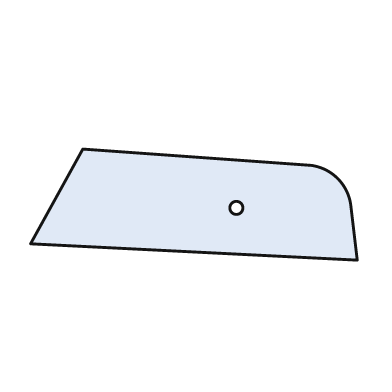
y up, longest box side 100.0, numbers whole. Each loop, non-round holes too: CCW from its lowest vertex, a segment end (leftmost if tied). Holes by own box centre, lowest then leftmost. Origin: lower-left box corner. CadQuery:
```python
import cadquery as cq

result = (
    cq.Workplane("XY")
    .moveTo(100.0, 0.0)
    .lineTo(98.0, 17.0)
    .threePointArc((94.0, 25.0), (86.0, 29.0))
    .lineTo(16.0, 34.0)
    .lineTo(0.0, 5.0)
    .close()
    .moveTo(63.0, 16.0)
    .circle(2.0)
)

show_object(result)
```